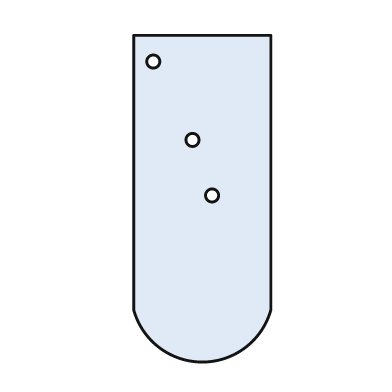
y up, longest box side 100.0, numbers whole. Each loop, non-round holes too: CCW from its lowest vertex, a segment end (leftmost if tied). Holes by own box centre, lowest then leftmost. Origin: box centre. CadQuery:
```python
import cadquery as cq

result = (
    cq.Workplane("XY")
    .moveTo(-21.0, -34.0)
    .threePointArc((0.0, -50.0), (21.0, -34.0))
    .lineTo(21.0, 50.0)
    .lineTo(-21.0, 50.0)
    .close()
    .moveTo(3.0, 1.0)
    .circle(2.0)
    .moveTo(-3.0, 18.0)
    .circle(2.0)
    .moveTo(-15.0, 42.0)
    .circle(2.0)
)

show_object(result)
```